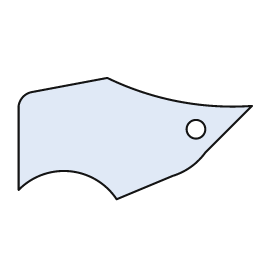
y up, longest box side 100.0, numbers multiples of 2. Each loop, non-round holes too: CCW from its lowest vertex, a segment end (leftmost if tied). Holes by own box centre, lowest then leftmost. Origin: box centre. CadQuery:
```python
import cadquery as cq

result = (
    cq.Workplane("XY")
    .moveTo(-8.0, -26.0)
    .lineTo(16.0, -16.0)
    .threePointArc((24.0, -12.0), (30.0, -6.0))
    .lineTo(50.0, 14.0)
    .threePointArc((18.0, 16.0), (-12.0, 26.0))
    .lineTo(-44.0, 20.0)
    .threePointArc((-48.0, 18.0), (-50.0, 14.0))
    .lineTo(-50.0, -22.0)
    .threePointArc((-28.0, -14.0), (-8.0, -26.0))
    .close()
    .moveTo(26.0, 4.0)
    .circle(4.0)
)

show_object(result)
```